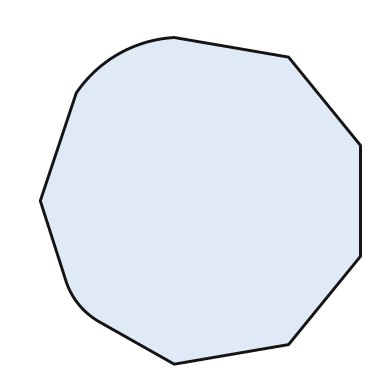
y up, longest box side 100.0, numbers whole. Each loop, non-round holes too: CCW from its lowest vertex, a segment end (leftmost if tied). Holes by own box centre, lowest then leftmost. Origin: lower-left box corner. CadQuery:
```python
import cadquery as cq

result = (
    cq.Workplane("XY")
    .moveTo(41.0, 0.0)
    .lineTo(76.0, 6.0)
    .lineTo(98.0, 33.0)
    .lineTo(98.0, 67.0)
    .lineTo(76.0, 94.0)
    .lineTo(41.0, 100.0)
    .threePointArc((24.0, 95.0), (11.0, 83.0))
    .lineTo(0.0, 50.0)
    .lineTo(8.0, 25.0)
    .threePointArc((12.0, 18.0), (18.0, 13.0))
    .close()
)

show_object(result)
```